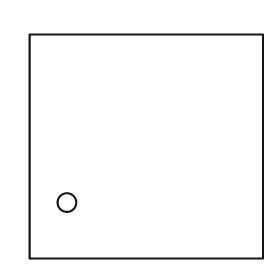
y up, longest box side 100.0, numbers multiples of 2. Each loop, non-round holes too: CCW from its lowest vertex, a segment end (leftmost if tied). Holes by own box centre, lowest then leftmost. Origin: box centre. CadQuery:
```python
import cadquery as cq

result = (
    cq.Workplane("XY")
    .moveTo(-50.0, -48.0)
    .lineTo(50.0, -48.0)
    .lineTo(50.0, 48.0)
    .lineTo(-50.0, 48.0)
    .close()
    .moveTo(-34.0, -24.0)
    .circle(4.0)
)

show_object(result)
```